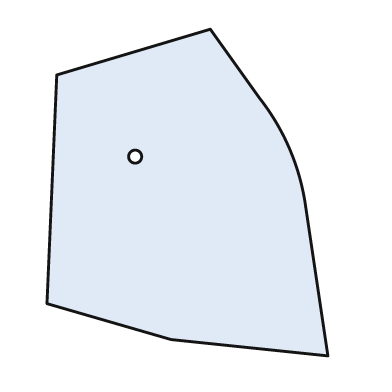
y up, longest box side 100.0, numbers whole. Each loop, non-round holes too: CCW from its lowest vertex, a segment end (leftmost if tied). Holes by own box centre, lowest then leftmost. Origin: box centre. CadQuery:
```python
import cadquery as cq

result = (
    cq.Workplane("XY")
    .moveTo(43.0, -50.0)
    .lineTo(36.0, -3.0)
    .threePointArc((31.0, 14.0), (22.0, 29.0))
    .lineTo(7.0, 50.0)
    .lineTo(-40.0, 36.0)
    .lineTo(-43.0, -34.0)
    .lineTo(-5.0, -45.0)
    .close()
    .moveTo(-16.0, 11.0)
    .circle(2.0)
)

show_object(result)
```